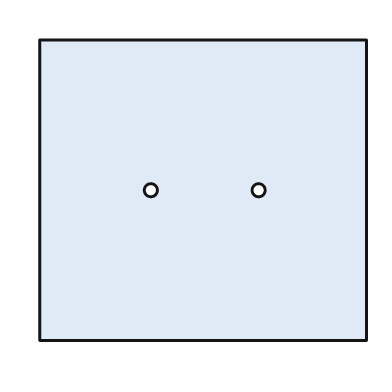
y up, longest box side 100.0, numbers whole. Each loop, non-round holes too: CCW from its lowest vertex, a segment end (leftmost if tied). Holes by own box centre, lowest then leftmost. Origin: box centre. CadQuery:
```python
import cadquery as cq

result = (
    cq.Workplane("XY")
    .moveTo(-50.0, -46.0)
    .lineTo(50.0, -46.0)
    .lineTo(50.0, 46.0)
    .lineTo(-50.0, 46.0)
    .close()
    .moveTo(-16.0, 0.0)
    .circle(2.0)
    .moveTo(17.0, 0.0)
    .circle(2.0)
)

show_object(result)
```